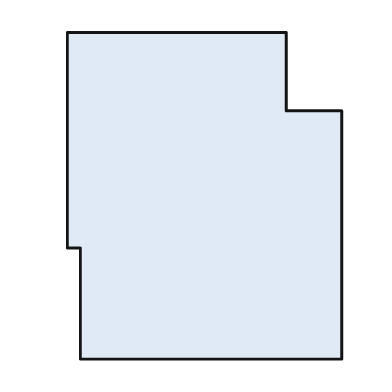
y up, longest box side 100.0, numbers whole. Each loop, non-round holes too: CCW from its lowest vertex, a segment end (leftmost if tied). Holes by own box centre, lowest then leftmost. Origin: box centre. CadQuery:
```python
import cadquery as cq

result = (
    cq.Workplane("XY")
    .moveTo(-38.0, -50.0)
    .lineTo(42.0, -50.0)
    .lineTo(42.0, 26.0)
    .lineTo(25.0, 26.0)
    .lineTo(25.0, 50.0)
    .lineTo(-42.0, 50.0)
    .lineTo(-42.0, -16.0)
    .lineTo(-38.0, -16.0)
    .close()
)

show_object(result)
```